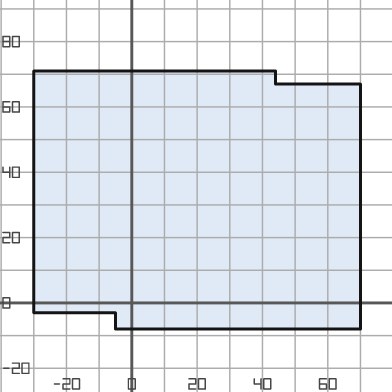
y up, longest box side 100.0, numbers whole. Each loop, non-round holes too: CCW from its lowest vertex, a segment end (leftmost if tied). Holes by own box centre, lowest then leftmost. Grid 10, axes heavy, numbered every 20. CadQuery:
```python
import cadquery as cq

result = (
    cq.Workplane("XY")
    .moveTo(-5.0, -8.0)
    .lineTo(70.0, -8.0)
    .lineTo(70.0, 67.0)
    .lineTo(44.0, 67.0)
    .lineTo(44.0, 71.0)
    .lineTo(-30.0, 71.0)
    .lineTo(-30.0, -3.0)
    .lineTo(-5.0, -3.0)
    .close()
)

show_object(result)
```